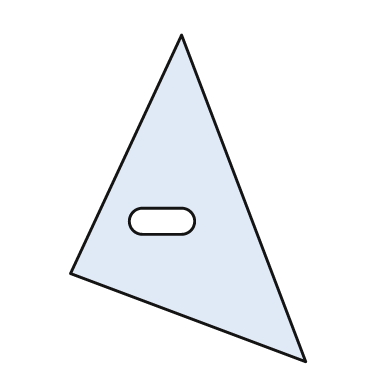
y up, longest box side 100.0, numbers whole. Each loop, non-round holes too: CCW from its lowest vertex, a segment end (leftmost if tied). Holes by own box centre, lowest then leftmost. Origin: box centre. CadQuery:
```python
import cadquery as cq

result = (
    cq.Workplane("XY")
    .moveTo(36.0, -50.0)
    .lineTo(-2.0, 50.0)
    .lineTo(-36.0, -23.0)
    .close()
    .moveTo(-14.0, -11.0)
    .lineTo(-2.0, -11.0)
    .threePointArc((2.0, -7.0), (-2.0, -3.0))
    .lineTo(-14.0, -3.0)
    .threePointArc((-18.0, -7.0), (-14.0, -11.0))
    .close()
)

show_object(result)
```